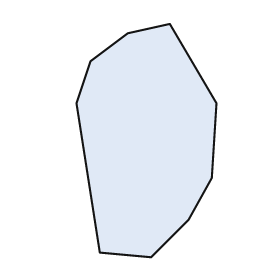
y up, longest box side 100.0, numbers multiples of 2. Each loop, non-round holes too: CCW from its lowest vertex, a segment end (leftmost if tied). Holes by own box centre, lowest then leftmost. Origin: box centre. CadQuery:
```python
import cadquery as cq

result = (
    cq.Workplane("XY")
    .moveTo(2.0, -50.0)
    .lineTo(18.0, -34.0)
    .lineTo(28.0, -16.0)
    .lineTo(30.0, 16.0)
    .lineTo(10.0, 50.0)
    .lineTo(-8.0, 46.0)
    .lineTo(-24.0, 34.0)
    .lineTo(-30.0, 16.0)
    .lineTo(-20.0, -48.0)
    .close()
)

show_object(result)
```